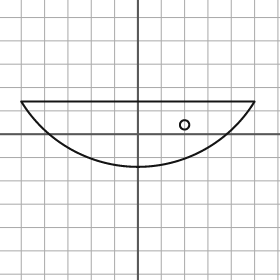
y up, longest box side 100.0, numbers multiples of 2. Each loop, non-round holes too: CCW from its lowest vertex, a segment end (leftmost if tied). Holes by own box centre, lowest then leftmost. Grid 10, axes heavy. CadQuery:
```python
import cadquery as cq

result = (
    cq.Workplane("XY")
    .moveTo(-50.0, 14.0)
    .threePointArc((0.0, -14.0), (50.0, 14.0))
    .close()
    .moveTo(20.0, 4.0)
    .circle(2.0)
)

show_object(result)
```